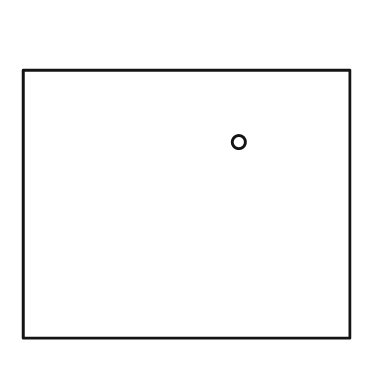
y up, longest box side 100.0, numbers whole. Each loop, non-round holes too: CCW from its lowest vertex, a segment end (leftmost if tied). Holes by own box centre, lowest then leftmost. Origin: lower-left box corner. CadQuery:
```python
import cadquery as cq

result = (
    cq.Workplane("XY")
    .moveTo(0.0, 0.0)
    .lineTo(100.0, 0.0)
    .lineTo(100.0, 82.0)
    .lineTo(0.0, 82.0)
    .close()
    .moveTo(66.0, 60.0)
    .circle(2.0)
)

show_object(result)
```